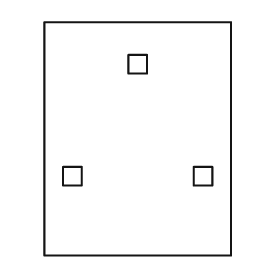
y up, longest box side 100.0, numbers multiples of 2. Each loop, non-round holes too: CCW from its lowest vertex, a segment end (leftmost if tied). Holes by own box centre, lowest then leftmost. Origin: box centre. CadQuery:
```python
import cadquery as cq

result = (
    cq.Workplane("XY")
    .moveTo(-40.0, -50.0)
    .lineTo(40.0, -50.0)
    .lineTo(40.0, 50.0)
    .lineTo(-40.0, 50.0)
    .close()
    .moveTo(-32.0, -20.0)
    .lineTo(-24.0, -20.0)
    .lineTo(-24.0, -12.0)
    .lineTo(-32.0, -12.0)
    .close()
    .moveTo(24.0, -20.0)
    .lineTo(32.0, -20.0)
    .lineTo(32.0, -12.0)
    .lineTo(24.0, -12.0)
    .close()
    .moveTo(-4.0, 28.0)
    .lineTo(4.0, 28.0)
    .lineTo(4.0, 36.0)
    .lineTo(-4.0, 36.0)
    .close()
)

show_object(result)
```